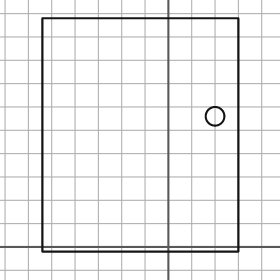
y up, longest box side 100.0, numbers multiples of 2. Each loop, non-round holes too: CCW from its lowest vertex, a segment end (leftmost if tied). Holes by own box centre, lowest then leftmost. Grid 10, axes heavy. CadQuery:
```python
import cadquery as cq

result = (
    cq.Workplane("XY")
    .moveTo(-54.0, -2.0)
    .lineTo(30.0, -2.0)
    .lineTo(30.0, 98.0)
    .lineTo(-54.0, 98.0)
    .close()
    .moveTo(20.0, 56.0)
    .circle(4.0)
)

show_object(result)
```